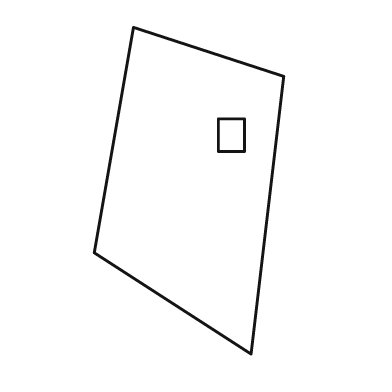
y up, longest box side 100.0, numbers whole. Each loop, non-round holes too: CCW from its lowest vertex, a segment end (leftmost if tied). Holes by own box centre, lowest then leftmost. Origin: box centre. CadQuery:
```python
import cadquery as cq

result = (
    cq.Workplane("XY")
    .moveTo(19.0, -50.0)
    .lineTo(29.0, 35.0)
    .lineTo(-17.0, 50.0)
    .lineTo(-29.0, -19.0)
    .close()
    .moveTo(9.0, 12.0)
    .lineTo(17.0, 12.0)
    .lineTo(17.0, 22.0)
    .lineTo(9.0, 22.0)
    .close()
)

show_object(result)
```